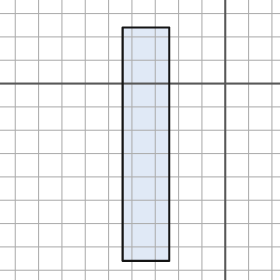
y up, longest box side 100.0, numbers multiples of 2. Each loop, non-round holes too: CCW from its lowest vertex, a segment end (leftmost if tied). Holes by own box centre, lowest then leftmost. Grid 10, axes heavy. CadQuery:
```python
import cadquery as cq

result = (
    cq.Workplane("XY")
    .moveTo(-44.0, -76.0)
    .lineTo(-24.0, -76.0)
    .lineTo(-24.0, 24.0)
    .lineTo(-44.0, 24.0)
    .close()
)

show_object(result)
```